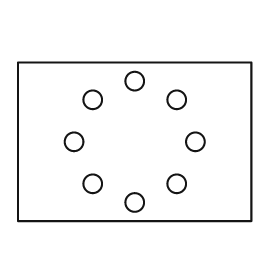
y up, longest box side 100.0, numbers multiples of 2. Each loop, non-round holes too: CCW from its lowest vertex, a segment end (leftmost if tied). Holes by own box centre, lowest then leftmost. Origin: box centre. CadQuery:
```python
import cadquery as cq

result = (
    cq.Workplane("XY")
    .moveTo(-50.0, -34.0)
    .lineTo(50.0, -34.0)
    .lineTo(50.0, 34.0)
    .lineTo(-50.0, 34.0)
    .close()
    .moveTo(0.0, -26.0)
    .circle(4.0)
    .moveTo(-18.0, -18.0)
    .circle(4.0)
    .moveTo(18.0, -18.0)
    .circle(4.0)
    .moveTo(-26.0, 0.0)
    .circle(4.0)
    .moveTo(26.0, 0.0)
    .circle(4.0)
    .moveTo(-18.0, 18.0)
    .circle(4.0)
    .moveTo(18.0, 18.0)
    .circle(4.0)
    .moveTo(0.0, 26.0)
    .circle(4.0)
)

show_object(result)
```